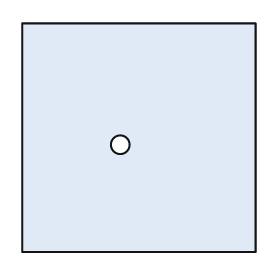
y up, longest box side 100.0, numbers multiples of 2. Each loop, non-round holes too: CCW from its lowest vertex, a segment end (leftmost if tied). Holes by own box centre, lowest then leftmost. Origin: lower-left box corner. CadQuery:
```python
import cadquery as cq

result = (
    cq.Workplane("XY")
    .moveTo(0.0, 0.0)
    .lineTo(100.0, 0.0)
    .lineTo(100.0, 98.0)
    .lineTo(0.0, 98.0)
    .close()
    .moveTo(42.0, 46.0)
    .circle(4.0)
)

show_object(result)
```